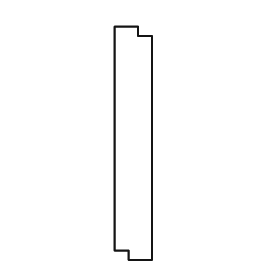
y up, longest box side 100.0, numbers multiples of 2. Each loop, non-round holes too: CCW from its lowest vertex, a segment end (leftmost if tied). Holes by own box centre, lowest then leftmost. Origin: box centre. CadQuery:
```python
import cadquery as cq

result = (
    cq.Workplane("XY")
    .moveTo(-2.0, -50.0)
    .lineTo(8.0, -50.0)
    .lineTo(8.0, 46.0)
    .lineTo(2.0, 46.0)
    .lineTo(2.0, 50.0)
    .lineTo(-8.0, 50.0)
    .lineTo(-8.0, -46.0)
    .lineTo(-2.0, -46.0)
    .close()
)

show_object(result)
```